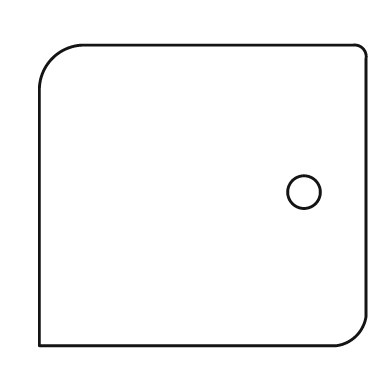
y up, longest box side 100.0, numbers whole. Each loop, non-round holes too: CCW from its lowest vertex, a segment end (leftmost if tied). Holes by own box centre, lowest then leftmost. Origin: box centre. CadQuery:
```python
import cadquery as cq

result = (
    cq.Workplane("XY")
    .moveTo(-50.0, -46.0)
    .lineTo(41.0, -46.0)
    .threePointArc((47.0, -43.0), (50.0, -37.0))
    .lineTo(50.0, 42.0)
    .threePointArc((49.0, 45.0), (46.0, 46.0))
    .lineTo(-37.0, 46.0)
    .threePointArc((-46.0, 42.0), (-50.0, 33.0))
    .close()
    .moveTo(31.0, 1.0)
    .circle(5.0)
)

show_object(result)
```